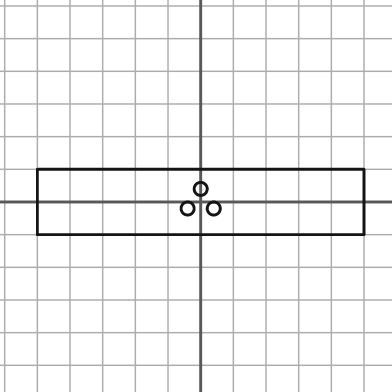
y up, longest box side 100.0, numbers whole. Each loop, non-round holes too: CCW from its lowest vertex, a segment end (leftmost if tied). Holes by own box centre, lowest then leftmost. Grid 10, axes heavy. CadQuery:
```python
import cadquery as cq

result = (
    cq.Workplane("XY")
    .moveTo(-50.0, -10.0)
    .lineTo(50.0, -10.0)
    .lineTo(50.0, 10.0)
    .lineTo(-50.0, 10.0)
    .close()
    .moveTo(-4.0, -2.0)
    .circle(2.0)
    .moveTo(4.0, -2.0)
    .circle(2.0)
    .moveTo(0.0, 4.0)
    .circle(2.0)
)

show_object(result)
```